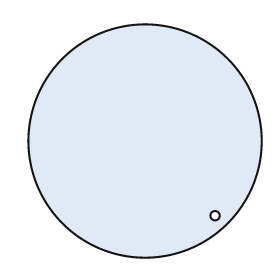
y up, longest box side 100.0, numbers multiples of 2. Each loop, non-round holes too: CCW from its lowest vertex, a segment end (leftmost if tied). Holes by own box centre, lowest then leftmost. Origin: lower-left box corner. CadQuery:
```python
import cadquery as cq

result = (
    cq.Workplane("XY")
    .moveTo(50.0, 50.0)
    .circle(50.0)
    .moveTo(80.0, 18.0)
    .circle(2.0)
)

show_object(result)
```